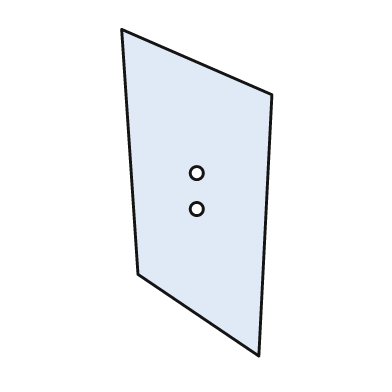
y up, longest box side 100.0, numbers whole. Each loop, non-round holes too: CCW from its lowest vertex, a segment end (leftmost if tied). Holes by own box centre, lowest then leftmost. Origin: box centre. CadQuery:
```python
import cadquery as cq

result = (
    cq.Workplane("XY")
    .moveTo(19.0, -50.0)
    .lineTo(23.0, 30.0)
    .lineTo(-23.0, 50.0)
    .lineTo(-18.0, -25.0)
    .close()
    .moveTo(0.0, -5.0)
    .circle(2.0)
    .moveTo(0.0, 6.0)
    .circle(2.0)
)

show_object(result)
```